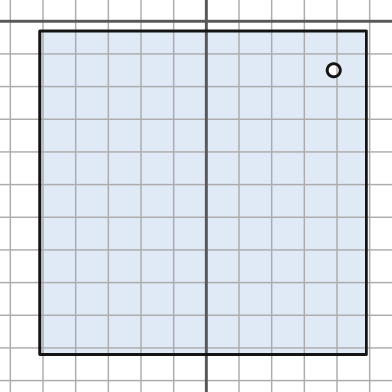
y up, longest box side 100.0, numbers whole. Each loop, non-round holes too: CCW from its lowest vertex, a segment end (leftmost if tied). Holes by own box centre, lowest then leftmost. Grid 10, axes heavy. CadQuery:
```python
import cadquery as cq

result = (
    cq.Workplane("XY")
    .moveTo(-51.0, -102.0)
    .lineTo(49.0, -102.0)
    .lineTo(49.0, -3.0)
    .lineTo(-51.0, -3.0)
    .close()
    .moveTo(39.0, -15.0)
    .circle(2.0)
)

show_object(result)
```